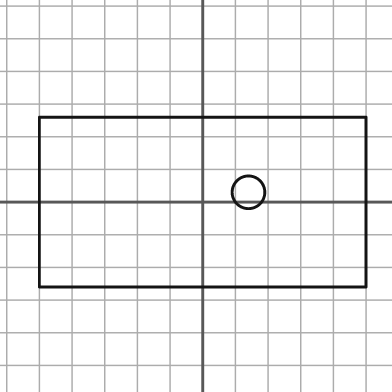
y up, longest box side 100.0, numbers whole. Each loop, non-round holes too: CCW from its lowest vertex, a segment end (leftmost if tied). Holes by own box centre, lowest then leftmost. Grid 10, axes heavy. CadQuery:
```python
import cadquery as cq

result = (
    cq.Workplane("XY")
    .moveTo(-50.0, -26.0)
    .lineTo(50.0, -26.0)
    .lineTo(50.0, 26.0)
    .lineTo(-50.0, 26.0)
    .close()
    .moveTo(14.0, 3.0)
    .circle(5.0)
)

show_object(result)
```